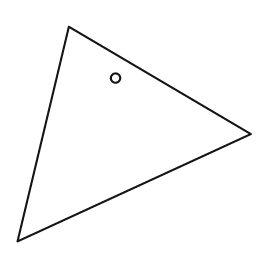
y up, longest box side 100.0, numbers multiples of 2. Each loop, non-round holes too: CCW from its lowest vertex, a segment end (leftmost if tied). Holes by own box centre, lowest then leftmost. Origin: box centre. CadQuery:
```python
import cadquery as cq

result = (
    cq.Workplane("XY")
    .moveTo(-50.0, -46.0)
    .lineTo(50.0, 0.0)
    .lineTo(-28.0, 46.0)
    .close()
    .moveTo(-8.0, 24.0)
    .circle(2.0)
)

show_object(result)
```